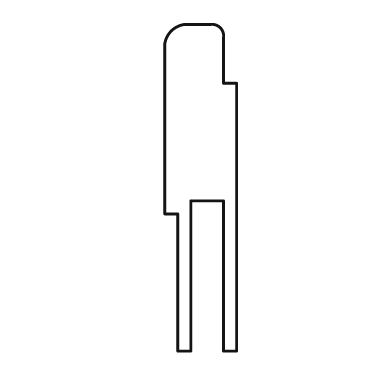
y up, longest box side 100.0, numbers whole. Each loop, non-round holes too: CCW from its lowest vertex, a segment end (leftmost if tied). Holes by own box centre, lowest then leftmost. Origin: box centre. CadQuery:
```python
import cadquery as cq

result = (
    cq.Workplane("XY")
    .moveTo(-7.0, -50.0)
    .lineTo(-3.0, -50.0)
    .lineTo(-3.0, -4.0)
    .lineTo(7.0, -4.0)
    .lineTo(7.0, -50.0)
    .lineTo(11.0, -50.0)
    .lineTo(11.0, 32.0)
    .lineTo(7.0, 32.0)
    .lineTo(7.0, 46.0)
    .threePointArc((6.0, 49.0), (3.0, 50.0))
    .lineTo(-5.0, 50.0)
    .threePointArc((-9.0, 48.0), (-11.0, 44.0))
    .lineTo(-11.0, -8.0)
    .lineTo(-7.0, -8.0)
    .close()
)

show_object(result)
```